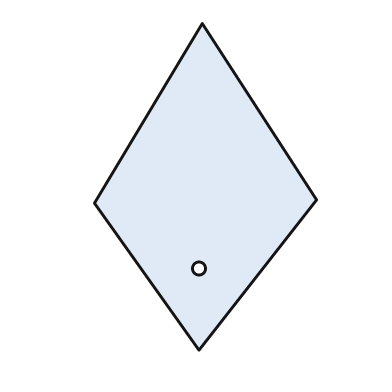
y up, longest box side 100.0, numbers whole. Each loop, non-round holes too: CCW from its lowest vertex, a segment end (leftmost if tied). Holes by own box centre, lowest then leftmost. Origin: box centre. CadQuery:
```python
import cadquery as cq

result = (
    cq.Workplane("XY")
    .moveTo(-2.0, -50.0)
    .lineTo(34.0, -4.0)
    .lineTo(-1.0, 50.0)
    .lineTo(-34.0, -5.0)
    .close()
    .moveTo(-2.0, -25.0)
    .circle(2.0)
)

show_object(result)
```